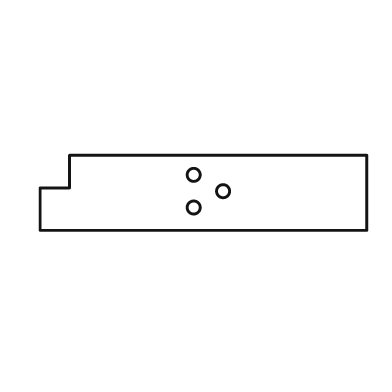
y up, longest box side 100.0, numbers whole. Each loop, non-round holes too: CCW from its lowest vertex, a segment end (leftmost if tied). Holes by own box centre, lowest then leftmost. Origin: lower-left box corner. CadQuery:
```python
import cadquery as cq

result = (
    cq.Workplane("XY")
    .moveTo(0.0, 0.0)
    .lineTo(100.0, 0.0)
    .lineTo(100.0, 23.0)
    .lineTo(9.0, 23.0)
    .lineTo(9.0, 13.0)
    .lineTo(0.0, 13.0)
    .close()
    .moveTo(47.0, 7.0)
    .circle(2.0)
    .moveTo(56.0, 12.0)
    .circle(2.0)
    .moveTo(47.0, 17.0)
    .circle(2.0)
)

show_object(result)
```